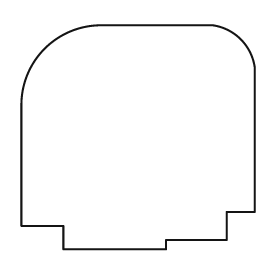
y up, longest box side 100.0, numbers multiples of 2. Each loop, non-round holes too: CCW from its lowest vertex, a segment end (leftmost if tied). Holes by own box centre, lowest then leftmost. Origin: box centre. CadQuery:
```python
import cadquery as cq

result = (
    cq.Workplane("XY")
    .moveTo(-32.0, -48.0)
    .lineTo(12.0, -48.0)
    .lineTo(12.0, -44.0)
    .lineTo(38.0, -44.0)
    .lineTo(38.0, -32.0)
    .lineTo(50.0, -32.0)
    .lineTo(50.0, 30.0)
    .threePointArc((44.0, 42.0), (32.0, 48.0))
    .lineTo(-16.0, 48.0)
    .threePointArc((-40.0, 38.0), (-50.0, 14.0))
    .lineTo(-50.0, -38.0)
    .lineTo(-32.0, -38.0)
    .close()
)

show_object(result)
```